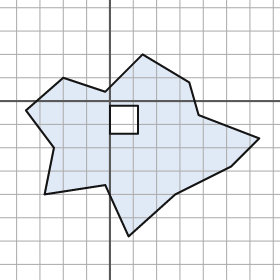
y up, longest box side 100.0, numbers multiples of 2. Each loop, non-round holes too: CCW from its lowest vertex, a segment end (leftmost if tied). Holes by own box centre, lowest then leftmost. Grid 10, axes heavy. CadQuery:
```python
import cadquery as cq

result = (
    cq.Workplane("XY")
    .moveTo(8.0, -58.0)
    .lineTo(28.0, -40.0)
    .lineTo(52.0, -28.0)
    .lineTo(64.0, -16.0)
    .lineTo(38.0, -6.0)
    .lineTo(34.0, 8.0)
    .lineTo(14.0, 20.0)
    .lineTo(-2.0, 4.0)
    .lineTo(-20.0, 10.0)
    .lineTo(-36.0, -4.0)
    .lineTo(-24.0, -20.0)
    .lineTo(-28.0, -40.0)
    .lineTo(-2.0, -36.0)
    .close()
    .moveTo(0.0, -14.0)
    .lineTo(12.0, -14.0)
    .lineTo(12.0, -2.0)
    .lineTo(0.0, -2.0)
    .close()
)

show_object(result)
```